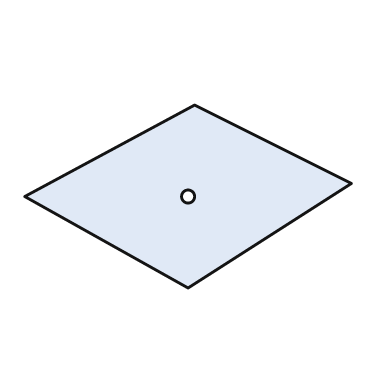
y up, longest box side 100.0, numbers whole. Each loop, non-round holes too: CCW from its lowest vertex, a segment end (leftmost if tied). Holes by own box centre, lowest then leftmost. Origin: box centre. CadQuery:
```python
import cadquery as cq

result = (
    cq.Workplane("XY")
    .moveTo(0.0, -28.0)
    .lineTo(50.0, 4.0)
    .lineTo(2.0, 28.0)
    .lineTo(-50.0, 0.0)
    .close()
    .moveTo(0.0, 0.0)
    .circle(2.0)
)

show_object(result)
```